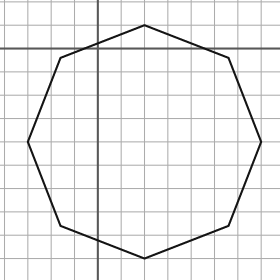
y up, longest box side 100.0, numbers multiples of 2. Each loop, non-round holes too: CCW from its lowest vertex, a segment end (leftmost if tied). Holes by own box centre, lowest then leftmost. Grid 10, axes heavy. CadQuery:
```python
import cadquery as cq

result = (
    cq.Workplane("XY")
    .moveTo(20.0, -90.0)
    .lineTo(56.0, -76.0)
    .lineTo(70.0, -40.0)
    .lineTo(56.0, -4.0)
    .lineTo(20.0, 10.0)
    .lineTo(-16.0, -4.0)
    .lineTo(-30.0, -40.0)
    .lineTo(-16.0, -76.0)
    .close()
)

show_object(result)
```